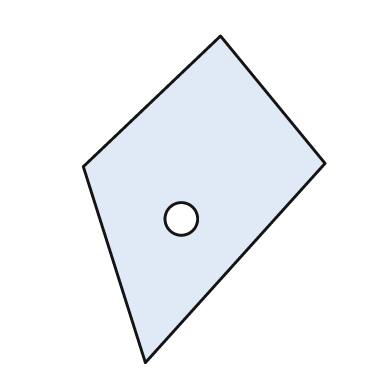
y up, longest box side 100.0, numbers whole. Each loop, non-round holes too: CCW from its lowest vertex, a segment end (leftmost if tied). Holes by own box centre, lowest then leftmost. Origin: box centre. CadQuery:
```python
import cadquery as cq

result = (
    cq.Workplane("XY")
    .moveTo(-18.0, -50.0)
    .lineTo(37.0, 11.0)
    .lineTo(5.0, 50.0)
    .lineTo(-37.0, 10.0)
    .close()
    .moveTo(-7.0, -6.0)
    .circle(5.0)
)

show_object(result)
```